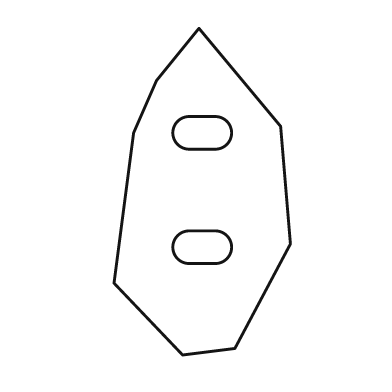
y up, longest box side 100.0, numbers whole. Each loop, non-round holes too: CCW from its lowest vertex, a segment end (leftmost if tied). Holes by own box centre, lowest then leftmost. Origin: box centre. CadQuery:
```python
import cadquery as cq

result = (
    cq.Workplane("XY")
    .moveTo(-6.0, -50.0)
    .lineTo(10.0, -48.0)
    .lineTo(27.0, -16.0)
    .lineTo(24.0, 20.0)
    .lineTo(-1.0, 50.0)
    .lineTo(-14.0, 34.0)
    .lineTo(-21.0, 18.0)
    .lineTo(-27.0, -28.0)
    .close()
    .moveTo(-4.0, -22.0)
    .lineTo(4.0, -22.0)
    .threePointArc((9.0, -17.0), (4.0, -12.0))
    .lineTo(-4.0, -12.0)
    .threePointArc((-9.0, -17.0), (-4.0, -22.0))
    .close()
    .moveTo(-4.0, 13.0)
    .lineTo(4.0, 13.0)
    .threePointArc((9.0, 18.0), (4.0, 23.0))
    .lineTo(-4.0, 23.0)
    .threePointArc((-9.0, 18.0), (-4.0, 13.0))
    .close()
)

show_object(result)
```